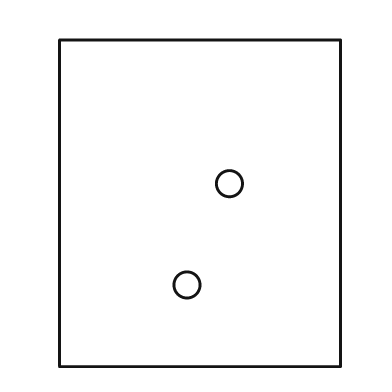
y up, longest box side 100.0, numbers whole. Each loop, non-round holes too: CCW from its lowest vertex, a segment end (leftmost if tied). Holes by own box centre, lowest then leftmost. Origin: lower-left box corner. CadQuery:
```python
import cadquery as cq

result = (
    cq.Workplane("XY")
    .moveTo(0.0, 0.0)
    .lineTo(86.0, 0.0)
    .lineTo(86.0, 100.0)
    .lineTo(0.0, 100.0)
    .close()
    .moveTo(39.0, 25.0)
    .circle(4.0)
    .moveTo(52.0, 56.0)
    .circle(4.0)
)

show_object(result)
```